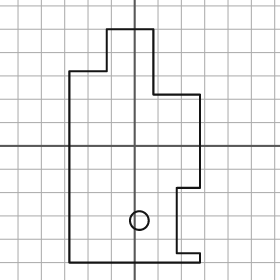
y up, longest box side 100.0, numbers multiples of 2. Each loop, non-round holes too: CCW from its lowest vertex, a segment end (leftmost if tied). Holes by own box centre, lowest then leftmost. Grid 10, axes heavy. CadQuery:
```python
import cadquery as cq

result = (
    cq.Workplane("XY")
    .moveTo(-28.0, -50.0)
    .lineTo(28.0, -50.0)
    .lineTo(28.0, -46.0)
    .lineTo(18.0, -46.0)
    .lineTo(18.0, -18.0)
    .lineTo(28.0, -18.0)
    .lineTo(28.0, 22.0)
    .lineTo(8.0, 22.0)
    .lineTo(8.0, 50.0)
    .lineTo(-12.0, 50.0)
    .lineTo(-12.0, 32.0)
    .lineTo(-28.0, 32.0)
    .close()
    .moveTo(2.0, -32.0)
    .circle(4.0)
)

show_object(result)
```